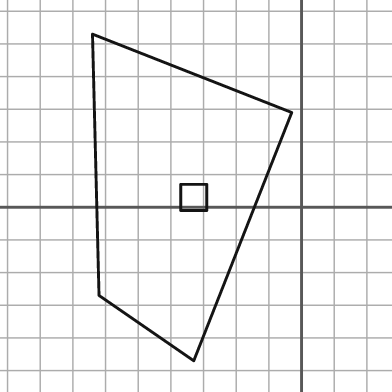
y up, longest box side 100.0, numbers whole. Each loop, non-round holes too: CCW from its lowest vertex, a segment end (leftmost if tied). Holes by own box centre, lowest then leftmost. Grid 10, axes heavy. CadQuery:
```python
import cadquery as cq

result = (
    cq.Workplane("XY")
    .moveTo(-33.0, -47.0)
    .lineTo(-3.0, 29.0)
    .lineTo(-64.0, 53.0)
    .lineTo(-62.0, -27.0)
    .close()
    .moveTo(-37.0, -1.0)
    .lineTo(-29.0, -1.0)
    .lineTo(-29.0, 7.0)
    .lineTo(-37.0, 7.0)
    .close()
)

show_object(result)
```